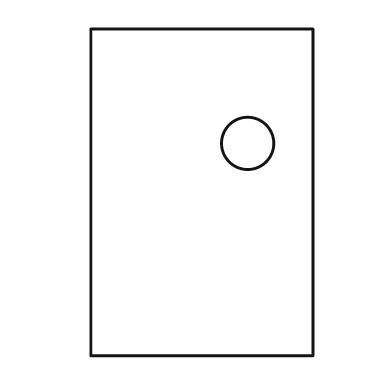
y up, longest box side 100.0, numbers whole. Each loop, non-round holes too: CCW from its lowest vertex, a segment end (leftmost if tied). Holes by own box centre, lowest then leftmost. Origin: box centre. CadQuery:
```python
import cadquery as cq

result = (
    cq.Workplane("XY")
    .moveTo(-34.0, -50.0)
    .lineTo(34.0, -50.0)
    .lineTo(34.0, 50.0)
    .lineTo(-34.0, 50.0)
    .close()
    .moveTo(14.0, 15.0)
    .circle(8.0)
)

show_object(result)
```